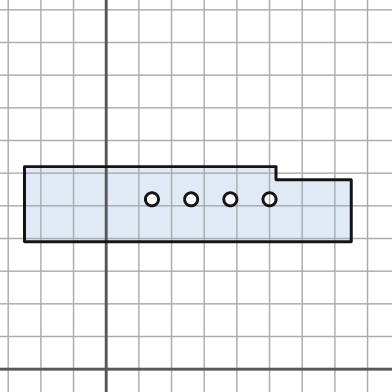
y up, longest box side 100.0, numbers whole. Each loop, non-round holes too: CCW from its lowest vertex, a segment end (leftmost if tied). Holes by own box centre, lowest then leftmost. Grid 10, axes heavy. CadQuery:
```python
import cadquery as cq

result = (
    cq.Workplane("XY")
    .moveTo(-25.0, 39.0)
    .lineTo(75.0, 39.0)
    .lineTo(75.0, 58.0)
    .lineTo(52.0, 58.0)
    .lineTo(52.0, 62.0)
    .lineTo(-25.0, 62.0)
    .close()
    .moveTo(14.0, 52.0)
    .circle(2.0)
    .moveTo(26.0, 52.0)
    .circle(2.0)
    .moveTo(38.0, 52.0)
    .circle(2.0)
    .moveTo(50.0, 52.0)
    .circle(2.0)
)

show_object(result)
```